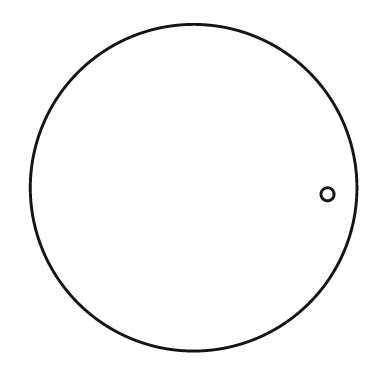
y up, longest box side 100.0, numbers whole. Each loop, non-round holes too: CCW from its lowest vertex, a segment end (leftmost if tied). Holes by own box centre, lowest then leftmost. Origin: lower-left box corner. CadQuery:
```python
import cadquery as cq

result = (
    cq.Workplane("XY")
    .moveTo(50.0, 50.0)
    .circle(50.0)
    .moveTo(91.0, 48.0)
    .circle(2.0)
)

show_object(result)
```